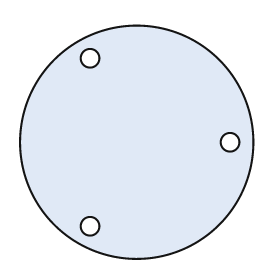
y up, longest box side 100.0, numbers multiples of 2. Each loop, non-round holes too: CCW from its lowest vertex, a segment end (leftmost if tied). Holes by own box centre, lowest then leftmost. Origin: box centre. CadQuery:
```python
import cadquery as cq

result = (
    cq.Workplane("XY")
    .moveTo(0.0, 0.0)
    .circle(50.0)
    .moveTo(-20.0, -36.0)
    .circle(4.0)
    .moveTo(40.0, 0.0)
    .circle(4.0)
    .moveTo(-20.0, 36.0)
    .circle(4.0)
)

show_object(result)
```